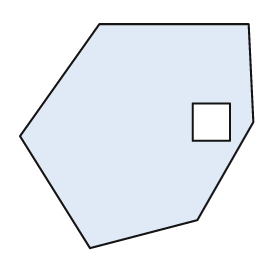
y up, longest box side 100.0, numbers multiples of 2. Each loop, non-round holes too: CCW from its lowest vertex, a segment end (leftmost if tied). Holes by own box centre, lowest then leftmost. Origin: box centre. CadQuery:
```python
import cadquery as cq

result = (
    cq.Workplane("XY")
    .moveTo(-20.0, -48.0)
    .lineTo(26.0, -36.0)
    .lineTo(50.0, 6.0)
    .lineTo(48.0, 48.0)
    .lineTo(-16.0, 48.0)
    .lineTo(-50.0, 0.0)
    .close()
    .moveTo(24.0, -2.0)
    .lineTo(40.0, -2.0)
    .lineTo(40.0, 14.0)
    .lineTo(24.0, 14.0)
    .close()
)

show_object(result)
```